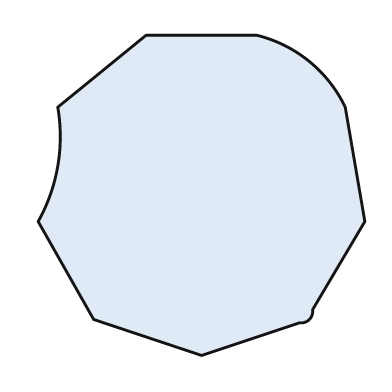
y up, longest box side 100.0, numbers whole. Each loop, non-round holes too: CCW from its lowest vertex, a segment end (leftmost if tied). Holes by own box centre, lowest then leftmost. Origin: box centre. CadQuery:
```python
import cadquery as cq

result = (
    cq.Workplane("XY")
    .moveTo(0.0, -49.0)
    .lineTo(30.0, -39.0)
    .threePointArc((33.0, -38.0), (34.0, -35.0))
    .lineTo(50.0, -8.0)
    .lineTo(44.0, 27.0)
    .threePointArc((33.0, 41.0), (17.0, 49.0))
    .lineTo(-17.0, 49.0)
    .lineTo(-44.0, 27.0)
    .threePointArc((-44.0, 9.0), (-50.0, -8.0))
    .lineTo(-33.0, -38.0)
    .close()
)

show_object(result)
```